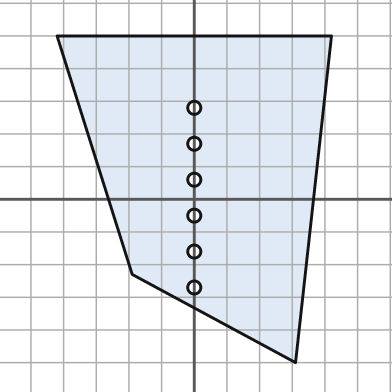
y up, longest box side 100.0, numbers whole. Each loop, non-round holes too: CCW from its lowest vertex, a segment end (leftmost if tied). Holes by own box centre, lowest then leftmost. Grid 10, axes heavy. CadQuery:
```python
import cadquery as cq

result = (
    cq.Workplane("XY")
    .moveTo(31.0, -50.0)
    .lineTo(42.0, 50.0)
    .lineTo(-42.0, 50.0)
    .lineTo(-19.0, -23.0)
    .close()
    .moveTo(0.0, -27.0)
    .circle(2.0)
    .moveTo(0.0, -16.0)
    .circle(2.0)
    .moveTo(0.0, -5.0)
    .circle(2.0)
    .moveTo(0.0, 6.0)
    .circle(2.0)
    .moveTo(0.0, 17.0)
    .circle(2.0)
    .moveTo(0.0, 28.0)
    .circle(2.0)
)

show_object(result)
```